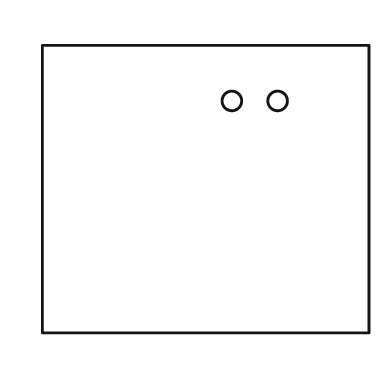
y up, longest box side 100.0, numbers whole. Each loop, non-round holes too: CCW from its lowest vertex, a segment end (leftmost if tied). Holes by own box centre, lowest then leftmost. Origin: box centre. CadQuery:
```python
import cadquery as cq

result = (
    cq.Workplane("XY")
    .moveTo(-50.0, -44.0)
    .lineTo(50.0, -44.0)
    .lineTo(50.0, 44.0)
    .lineTo(-50.0, 44.0)
    .close()
    .moveTo(8.0, 27.0)
    .circle(3.0)
    .moveTo(22.0, 27.0)
    .circle(3.0)
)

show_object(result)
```